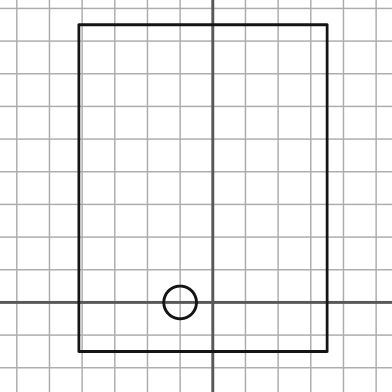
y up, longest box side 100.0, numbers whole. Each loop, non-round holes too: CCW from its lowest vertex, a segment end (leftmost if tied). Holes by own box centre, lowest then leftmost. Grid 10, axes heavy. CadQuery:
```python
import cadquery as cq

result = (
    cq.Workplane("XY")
    .moveTo(-41.0, -15.0)
    .lineTo(35.0, -15.0)
    .lineTo(35.0, 85.0)
    .lineTo(-41.0, 85.0)
    .close()
    .moveTo(-10.0, 0.0)
    .circle(5.0)
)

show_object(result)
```